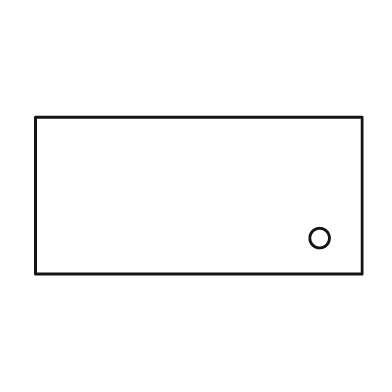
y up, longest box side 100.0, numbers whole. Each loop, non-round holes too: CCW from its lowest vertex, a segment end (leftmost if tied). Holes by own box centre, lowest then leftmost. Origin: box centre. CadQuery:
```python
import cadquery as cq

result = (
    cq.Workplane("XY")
    .moveTo(-50.0, -24.0)
    .lineTo(50.0, -24.0)
    .lineTo(50.0, 24.0)
    .lineTo(-50.0, 24.0)
    .close()
    .moveTo(37.0, -13.0)
    .circle(3.0)
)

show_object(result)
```